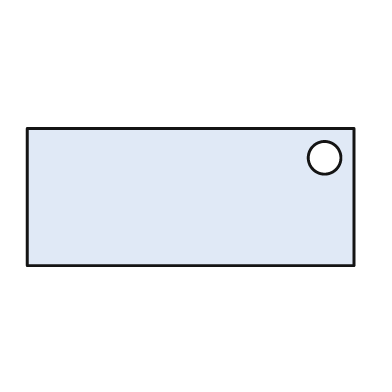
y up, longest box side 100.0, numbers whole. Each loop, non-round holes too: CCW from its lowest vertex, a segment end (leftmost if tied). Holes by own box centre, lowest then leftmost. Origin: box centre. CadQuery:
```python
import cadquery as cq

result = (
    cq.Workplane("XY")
    .moveTo(-50.0, -21.0)
    .lineTo(50.0, -21.0)
    .lineTo(50.0, 21.0)
    .lineTo(-50.0, 21.0)
    .close()
    .moveTo(41.0, 12.0)
    .circle(5.0)
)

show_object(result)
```